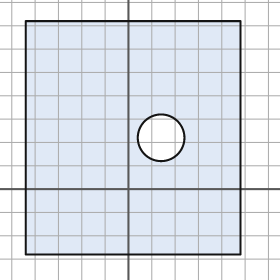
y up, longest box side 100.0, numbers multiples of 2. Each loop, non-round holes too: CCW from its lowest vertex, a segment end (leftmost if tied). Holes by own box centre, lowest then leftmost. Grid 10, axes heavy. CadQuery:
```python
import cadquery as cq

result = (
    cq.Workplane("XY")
    .moveTo(-44.0, -28.0)
    .lineTo(48.0, -28.0)
    .lineTo(48.0, 72.0)
    .lineTo(-44.0, 72.0)
    .close()
    .moveTo(14.0, 22.0)
    .circle(10.0)
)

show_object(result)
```